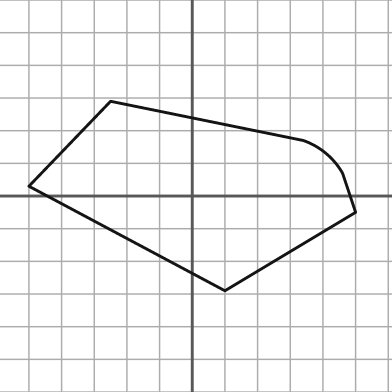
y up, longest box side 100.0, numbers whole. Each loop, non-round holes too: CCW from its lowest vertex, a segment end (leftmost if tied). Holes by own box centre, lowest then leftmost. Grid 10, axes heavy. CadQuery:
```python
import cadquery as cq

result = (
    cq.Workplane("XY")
    .moveTo(10.0, -29.0)
    .lineTo(50.0, -5.0)
    .lineTo(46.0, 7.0)
    .threePointArc((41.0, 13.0), (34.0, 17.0))
    .lineTo(-25.0, 29.0)
    .lineTo(-50.0, 3.0)
    .close()
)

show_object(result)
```